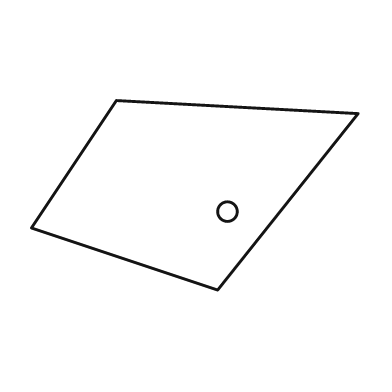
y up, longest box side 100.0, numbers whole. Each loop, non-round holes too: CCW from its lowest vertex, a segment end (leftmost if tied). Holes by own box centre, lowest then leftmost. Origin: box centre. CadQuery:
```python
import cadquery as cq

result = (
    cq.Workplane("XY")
    .moveTo(7.0, -29.0)
    .lineTo(50.0, 25.0)
    .lineTo(-24.0, 29.0)
    .lineTo(-50.0, -10.0)
    .close()
    .moveTo(10.0, -5.0)
    .circle(3.0)
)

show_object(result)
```